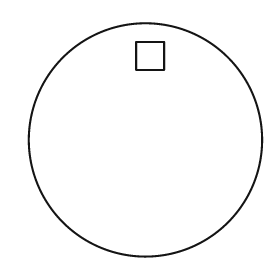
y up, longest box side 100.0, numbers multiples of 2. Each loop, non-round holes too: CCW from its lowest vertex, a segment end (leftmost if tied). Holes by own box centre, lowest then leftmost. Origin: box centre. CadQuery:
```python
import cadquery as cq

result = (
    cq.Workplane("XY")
    .moveTo(0.0, 0.0)
    .circle(50.0)
    .moveTo(-4.0, 30.0)
    .lineTo(8.0, 30.0)
    .lineTo(8.0, 42.0)
    .lineTo(-4.0, 42.0)
    .close()
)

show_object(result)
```